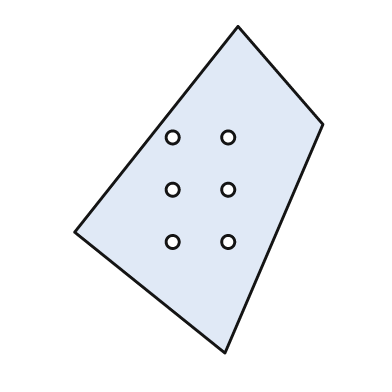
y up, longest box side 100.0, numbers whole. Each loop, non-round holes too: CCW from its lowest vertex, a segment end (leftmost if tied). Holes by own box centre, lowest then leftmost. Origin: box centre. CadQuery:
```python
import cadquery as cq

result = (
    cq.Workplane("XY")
    .moveTo(8.0, -50.0)
    .lineTo(38.0, 20.0)
    .lineTo(12.0, 50.0)
    .lineTo(-38.0, -13.0)
    .close()
    .moveTo(-8.0, -16.0)
    .circle(2.0)
    .moveTo(9.0, -16.0)
    .circle(2.0)
    .moveTo(-8.0, 0.0)
    .circle(2.0)
    .moveTo(9.0, 0.0)
    .circle(2.0)
    .moveTo(-8.0, 16.0)
    .circle(2.0)
    .moveTo(9.0, 16.0)
    .circle(2.0)
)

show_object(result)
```